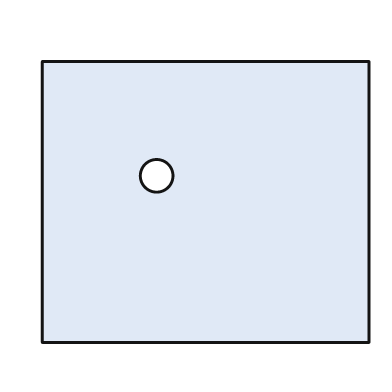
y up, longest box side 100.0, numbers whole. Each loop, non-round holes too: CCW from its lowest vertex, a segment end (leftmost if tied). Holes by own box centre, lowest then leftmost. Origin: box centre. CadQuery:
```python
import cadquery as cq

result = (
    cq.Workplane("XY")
    .moveTo(-50.0, -43.0)
    .lineTo(50.0, -43.0)
    .lineTo(50.0, 43.0)
    .lineTo(-50.0, 43.0)
    .close()
    .moveTo(-15.0, 8.0)
    .circle(5.0)
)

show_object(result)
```